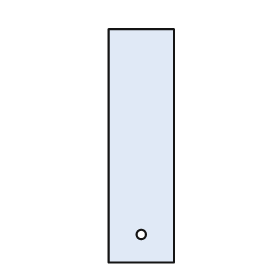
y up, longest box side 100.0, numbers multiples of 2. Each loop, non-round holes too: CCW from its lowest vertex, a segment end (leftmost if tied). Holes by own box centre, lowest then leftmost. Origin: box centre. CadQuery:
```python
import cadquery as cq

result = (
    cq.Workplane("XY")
    .moveTo(-14.0, -50.0)
    .lineTo(14.0, -50.0)
    .lineTo(14.0, 50.0)
    .lineTo(-14.0, 50.0)
    .close()
    .moveTo(0.0, -38.0)
    .circle(2.0)
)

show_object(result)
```